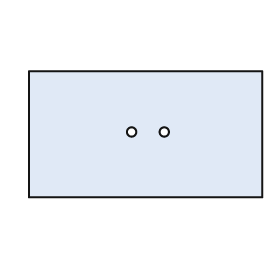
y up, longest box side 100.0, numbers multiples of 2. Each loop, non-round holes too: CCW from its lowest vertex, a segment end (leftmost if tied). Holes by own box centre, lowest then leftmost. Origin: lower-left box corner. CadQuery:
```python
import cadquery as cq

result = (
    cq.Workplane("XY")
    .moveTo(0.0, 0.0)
    .lineTo(100.0, 0.0)
    .lineTo(100.0, 54.0)
    .lineTo(0.0, 54.0)
    .close()
    .moveTo(44.0, 28.0)
    .circle(2.0)
    .moveTo(58.0, 28.0)
    .circle(2.0)
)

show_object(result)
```